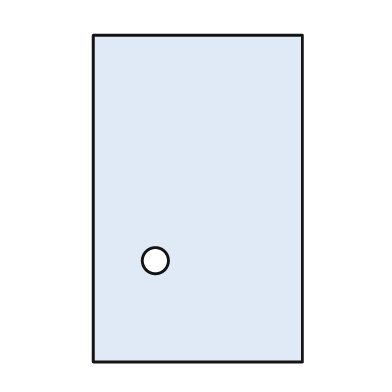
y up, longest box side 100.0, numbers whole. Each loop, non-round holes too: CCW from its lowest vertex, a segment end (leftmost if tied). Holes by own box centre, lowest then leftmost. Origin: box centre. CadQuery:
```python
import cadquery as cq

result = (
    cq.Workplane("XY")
    .moveTo(-32.0, -50.0)
    .lineTo(32.0, -50.0)
    .lineTo(32.0, 50.0)
    .lineTo(-32.0, 50.0)
    .close()
    .moveTo(-13.0, -19.0)
    .circle(4.0)
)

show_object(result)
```